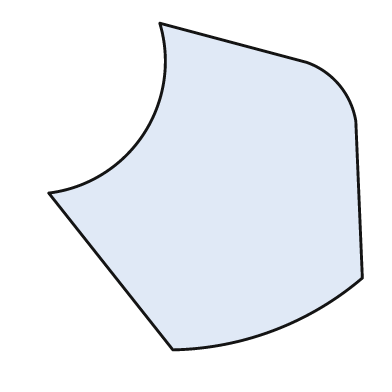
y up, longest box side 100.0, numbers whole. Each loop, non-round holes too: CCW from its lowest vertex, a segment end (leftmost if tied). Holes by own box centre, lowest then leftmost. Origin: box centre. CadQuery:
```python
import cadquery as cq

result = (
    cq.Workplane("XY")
    .moveTo(-10.0, -50.0)
    .threePointArc((21.0, -44.0), (48.0, -28.0))
    .lineTo(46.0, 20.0)
    .threePointArc((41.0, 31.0), (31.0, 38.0))
    .lineTo(-14.0, 50.0)
    .threePointArc((-19.0, 16.0), (-48.0, -2.0))
    .close()
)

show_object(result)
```